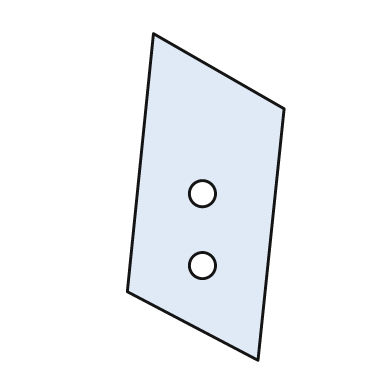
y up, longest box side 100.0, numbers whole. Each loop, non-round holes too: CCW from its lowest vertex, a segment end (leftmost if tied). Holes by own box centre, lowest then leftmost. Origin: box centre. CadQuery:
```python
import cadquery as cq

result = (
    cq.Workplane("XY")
    .moveTo(16.0, -50.0)
    .lineTo(24.0, 27.0)
    .lineTo(-16.0, 50.0)
    .lineTo(-24.0, -29.0)
    .close()
    .moveTo(-1.0, -21.0)
    .circle(4.0)
    .moveTo(-1.0, 1.0)
    .circle(4.0)
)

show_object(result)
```